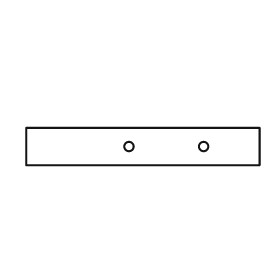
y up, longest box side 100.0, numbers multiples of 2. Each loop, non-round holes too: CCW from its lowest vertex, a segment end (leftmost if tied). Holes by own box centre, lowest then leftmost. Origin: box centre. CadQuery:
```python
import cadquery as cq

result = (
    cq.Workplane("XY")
    .moveTo(-50.0, -8.0)
    .lineTo(50.0, -8.0)
    .lineTo(50.0, 8.0)
    .lineTo(-50.0, 8.0)
    .close()
    .moveTo(-6.0, 0.0)
    .circle(2.0)
    .moveTo(26.0, 0.0)
    .circle(2.0)
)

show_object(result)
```